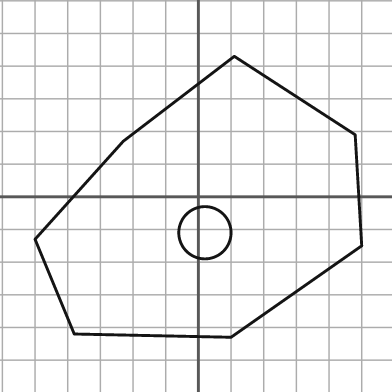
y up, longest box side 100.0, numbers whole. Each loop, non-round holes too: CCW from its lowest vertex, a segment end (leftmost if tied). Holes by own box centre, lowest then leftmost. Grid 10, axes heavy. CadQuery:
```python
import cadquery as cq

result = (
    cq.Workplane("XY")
    .moveTo(10.0, -43.0)
    .lineTo(50.0, -15.0)
    .lineTo(48.0, 19.0)
    .lineTo(11.0, 43.0)
    .lineTo(-23.0, 17.0)
    .lineTo(-50.0, -13.0)
    .lineTo(-38.0, -42.0)
    .close()
    .moveTo(2.0, -11.0)
    .circle(8.0)
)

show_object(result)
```